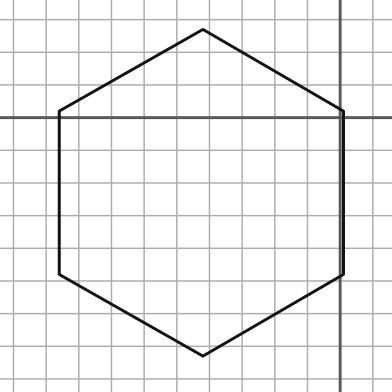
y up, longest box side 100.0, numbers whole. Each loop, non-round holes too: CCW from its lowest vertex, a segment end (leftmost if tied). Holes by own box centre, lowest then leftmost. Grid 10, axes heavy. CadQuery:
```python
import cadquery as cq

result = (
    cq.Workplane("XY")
    .moveTo(-42.0, -73.0)
    .lineTo(1.0, -48.0)
    .lineTo(1.0, 2.0)
    .lineTo(-42.0, 27.0)
    .lineTo(-86.0, 2.0)
    .lineTo(-86.0, -48.0)
    .close()
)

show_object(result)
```